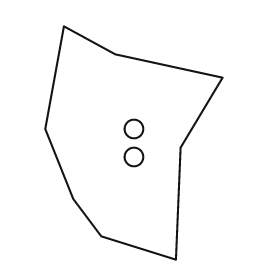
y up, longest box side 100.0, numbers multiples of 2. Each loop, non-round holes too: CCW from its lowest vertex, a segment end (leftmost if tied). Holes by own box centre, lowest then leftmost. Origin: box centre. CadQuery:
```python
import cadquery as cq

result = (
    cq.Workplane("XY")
    .moveTo(18.0, -50.0)
    .lineTo(20.0, -2.0)
    .lineTo(38.0, 28.0)
    .lineTo(-8.0, 38.0)
    .lineTo(-30.0, 50.0)
    .lineTo(-38.0, 6.0)
    .lineTo(-26.0, -24.0)
    .lineTo(-14.0, -40.0)
    .close()
    .moveTo(0.0, -6.0)
    .circle(4.0)
    .moveTo(0.0, 6.0)
    .circle(4.0)
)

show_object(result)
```